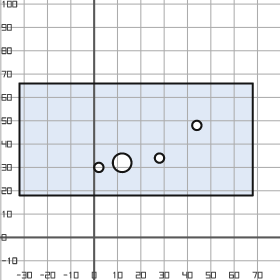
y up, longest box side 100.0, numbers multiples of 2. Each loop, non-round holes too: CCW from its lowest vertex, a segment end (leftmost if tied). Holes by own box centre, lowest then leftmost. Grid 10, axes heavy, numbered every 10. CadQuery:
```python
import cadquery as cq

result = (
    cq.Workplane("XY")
    .moveTo(-32.0, 18.0)
    .lineTo(68.0, 18.0)
    .lineTo(68.0, 66.0)
    .lineTo(-32.0, 66.0)
    .close()
    .moveTo(2.0, 30.0)
    .circle(2.0)
    .moveTo(12.0, 32.0)
    .circle(4.0)
    .moveTo(28.0, 34.0)
    .circle(2.0)
    .moveTo(44.0, 48.0)
    .circle(2.0)
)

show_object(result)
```